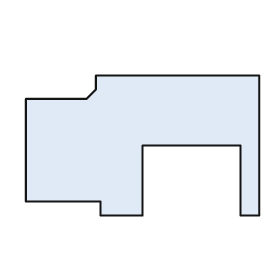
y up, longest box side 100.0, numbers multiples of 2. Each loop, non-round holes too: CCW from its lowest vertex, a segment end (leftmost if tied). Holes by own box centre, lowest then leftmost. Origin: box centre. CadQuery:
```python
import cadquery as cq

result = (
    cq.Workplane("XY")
    .moveTo(-18.0, -30.0)
    .lineTo(0.0, -30.0)
    .lineTo(0.0, 0.0)
    .lineTo(42.0, 0.0)
    .lineTo(42.0, -30.0)
    .lineTo(50.0, -30.0)
    .lineTo(50.0, 30.0)
    .lineTo(-20.0, 30.0)
    .lineTo(-20.0, 24.0)
    .lineTo(-24.0, 20.0)
    .lineTo(-50.0, 20.0)
    .lineTo(-50.0, -24.0)
    .lineTo(-18.0, -24.0)
    .close()
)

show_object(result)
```